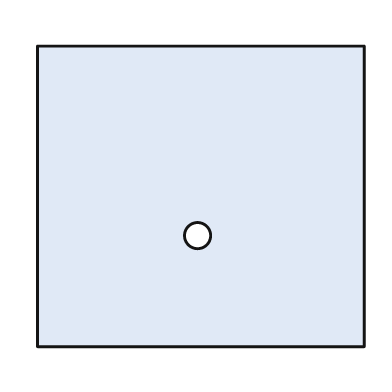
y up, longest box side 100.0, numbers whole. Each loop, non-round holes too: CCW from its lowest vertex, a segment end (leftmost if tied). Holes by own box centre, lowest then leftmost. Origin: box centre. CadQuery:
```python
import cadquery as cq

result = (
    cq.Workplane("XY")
    .moveTo(-50.0, -46.0)
    .lineTo(50.0, -46.0)
    .lineTo(50.0, 46.0)
    .lineTo(-50.0, 46.0)
    .close()
    .moveTo(-1.0, -12.0)
    .circle(4.0)
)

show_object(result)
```